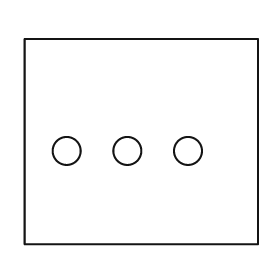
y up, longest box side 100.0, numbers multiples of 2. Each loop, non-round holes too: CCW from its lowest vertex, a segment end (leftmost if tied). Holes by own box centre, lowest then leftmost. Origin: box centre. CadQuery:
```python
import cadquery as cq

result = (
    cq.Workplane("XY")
    .moveTo(-50.0, -44.0)
    .lineTo(50.0, -44.0)
    .lineTo(50.0, 44.0)
    .lineTo(-50.0, 44.0)
    .close()
    .moveTo(-32.0, -4.0)
    .circle(6.0)
    .moveTo(-6.0, -4.0)
    .circle(6.0)
    .moveTo(20.0, -4.0)
    .circle(6.0)
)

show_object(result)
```